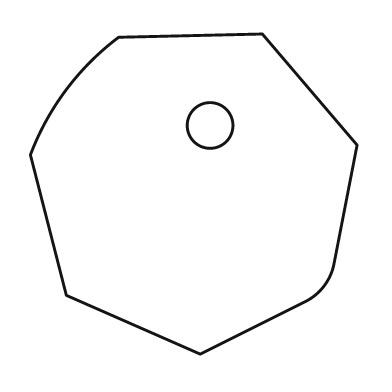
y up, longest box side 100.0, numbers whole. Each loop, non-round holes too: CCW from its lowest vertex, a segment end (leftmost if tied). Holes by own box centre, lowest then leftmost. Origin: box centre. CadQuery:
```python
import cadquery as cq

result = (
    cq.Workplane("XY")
    .moveTo(2.0, -49.0)
    .lineTo(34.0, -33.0)
    .threePointArc((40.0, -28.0), (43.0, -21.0))
    .lineTo(50.0, 15.0)
    .lineTo(21.0, 49.0)
    .lineTo(-23.0, 48.0)
    .threePointArc((-39.0, 32.0), (-50.0, 12.0))
    .lineTo(-39.0, -31.0)
    .close()
    .moveTo(5.0, 21.0)
    .circle(7.0)
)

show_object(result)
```